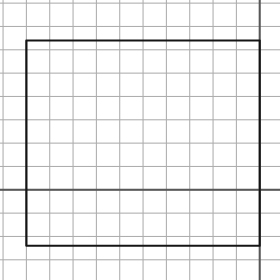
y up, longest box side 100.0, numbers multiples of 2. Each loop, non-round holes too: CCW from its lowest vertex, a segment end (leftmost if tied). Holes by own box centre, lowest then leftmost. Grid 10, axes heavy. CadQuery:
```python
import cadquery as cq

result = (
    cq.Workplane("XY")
    .moveTo(-100.0, -24.0)
    .lineTo(0.0, -24.0)
    .lineTo(0.0, 64.0)
    .lineTo(-100.0, 64.0)
    .close()
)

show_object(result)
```